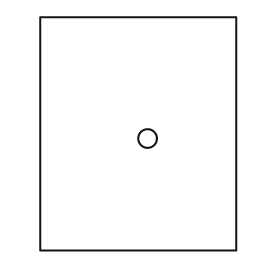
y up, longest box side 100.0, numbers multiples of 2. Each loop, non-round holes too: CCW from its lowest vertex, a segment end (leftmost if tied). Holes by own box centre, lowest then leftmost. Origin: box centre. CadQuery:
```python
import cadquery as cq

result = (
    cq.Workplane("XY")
    .moveTo(-42.0, -50.0)
    .lineTo(42.0, -50.0)
    .lineTo(42.0, 50.0)
    .lineTo(-42.0, 50.0)
    .close()
    .moveTo(4.0, -2.0)
    .circle(4.0)
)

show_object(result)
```